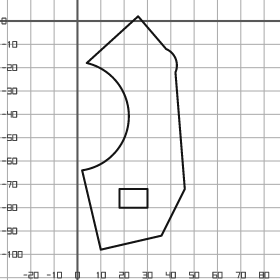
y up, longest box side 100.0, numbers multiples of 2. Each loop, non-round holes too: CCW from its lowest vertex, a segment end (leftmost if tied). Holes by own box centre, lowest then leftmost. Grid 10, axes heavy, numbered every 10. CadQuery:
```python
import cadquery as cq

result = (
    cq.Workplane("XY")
    .moveTo(10.0, -98.0)
    .lineTo(36.0, -92.0)
    .lineTo(46.0, -72.0)
    .lineTo(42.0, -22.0)
    .threePointArc((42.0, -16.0), (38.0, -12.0))
    .lineTo(26.0, 2.0)
    .lineTo(4.0, -18.0)
    .threePointArc((22.0, -42.0), (2.0, -64.0))
    .close()
    .moveTo(18.0, -80.0)
    .lineTo(30.0, -80.0)
    .lineTo(30.0, -72.0)
    .lineTo(18.0, -72.0)
    .close()
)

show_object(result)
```